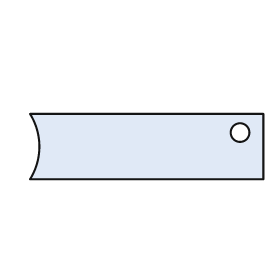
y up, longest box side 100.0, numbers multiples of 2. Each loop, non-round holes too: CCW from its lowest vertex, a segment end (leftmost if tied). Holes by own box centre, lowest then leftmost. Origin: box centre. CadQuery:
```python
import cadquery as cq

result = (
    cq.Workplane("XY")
    .moveTo(-50.0, -14.0)
    .lineTo(50.0, -14.0)
    .lineTo(50.0, 14.0)
    .lineTo(-50.0, 14.0)
    .threePointArc((-46.0, 0.0), (-50.0, -14.0))
    .close()
    .moveTo(40.0, 6.0)
    .circle(4.0)
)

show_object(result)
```